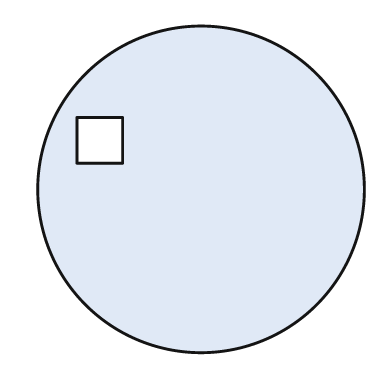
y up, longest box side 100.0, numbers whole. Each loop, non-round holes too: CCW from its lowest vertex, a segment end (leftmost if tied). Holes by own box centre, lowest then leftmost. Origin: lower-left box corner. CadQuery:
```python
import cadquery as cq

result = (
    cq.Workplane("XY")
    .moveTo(50.0, 50.0)
    .circle(50.0)
    .moveTo(12.0, 58.0)
    .lineTo(26.0, 58.0)
    .lineTo(26.0, 72.0)
    .lineTo(12.0, 72.0)
    .close()
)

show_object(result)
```